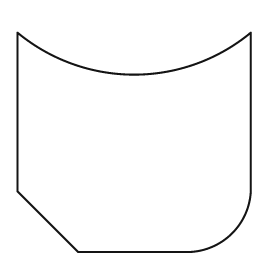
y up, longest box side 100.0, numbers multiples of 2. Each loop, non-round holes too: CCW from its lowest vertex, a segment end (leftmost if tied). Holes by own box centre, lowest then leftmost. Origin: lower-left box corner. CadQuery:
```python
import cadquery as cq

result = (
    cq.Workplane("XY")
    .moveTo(26.0, 0.0)
    .lineTo(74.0, 0.0)
    .threePointArc((92.0, 8.0), (100.0, 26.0))
    .lineTo(100.0, 94.0)
    .threePointArc((50.0, 76.0), (0.0, 94.0))
    .lineTo(0.0, 26.0)
    .close()
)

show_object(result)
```